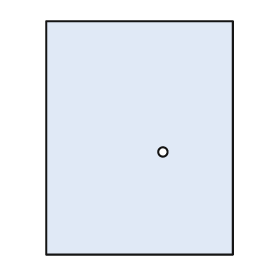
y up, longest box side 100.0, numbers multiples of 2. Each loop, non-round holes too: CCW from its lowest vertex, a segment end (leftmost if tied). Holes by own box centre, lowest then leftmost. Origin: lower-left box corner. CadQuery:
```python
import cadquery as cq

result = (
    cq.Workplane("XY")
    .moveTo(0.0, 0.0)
    .lineTo(80.0, 0.0)
    .lineTo(80.0, 100.0)
    .lineTo(0.0, 100.0)
    .close()
    .moveTo(50.0, 44.0)
    .circle(2.0)
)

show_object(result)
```